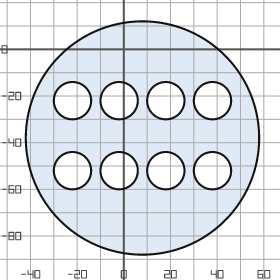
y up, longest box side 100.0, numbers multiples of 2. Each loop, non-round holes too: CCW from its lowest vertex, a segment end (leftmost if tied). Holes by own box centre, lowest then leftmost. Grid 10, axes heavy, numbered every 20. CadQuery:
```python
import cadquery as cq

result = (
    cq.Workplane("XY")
    .moveTo(8.0, -38.0)
    .circle(50.0)
    .moveTo(-22.0, -52.0)
    .circle(8.0)
    .moveTo(-2.0, -52.0)
    .circle(8.0)
    .moveTo(18.0, -52.0)
    .circle(8.0)
    .moveTo(38.0, -52.0)
    .circle(8.0)
    .moveTo(-22.0, -22.0)
    .circle(8.0)
    .moveTo(-2.0, -22.0)
    .circle(8.0)
    .moveTo(18.0, -22.0)
    .circle(8.0)
    .moveTo(38.0, -22.0)
    .circle(8.0)
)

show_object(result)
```